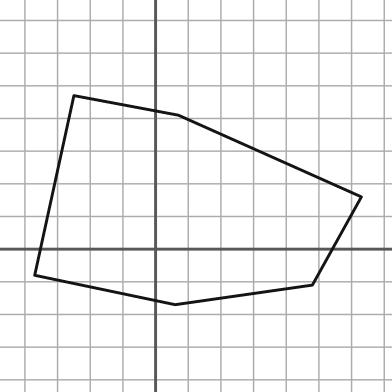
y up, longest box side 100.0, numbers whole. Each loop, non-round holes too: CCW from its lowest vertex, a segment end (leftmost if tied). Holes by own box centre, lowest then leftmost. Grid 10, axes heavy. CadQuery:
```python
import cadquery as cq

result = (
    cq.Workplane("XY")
    .moveTo(6.0, -17.0)
    .lineTo(48.0, -11.0)
    .lineTo(63.0, 16.0)
    .lineTo(7.0, 41.0)
    .lineTo(-25.0, 47.0)
    .lineTo(-37.0, -8.0)
    .close()
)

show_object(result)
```